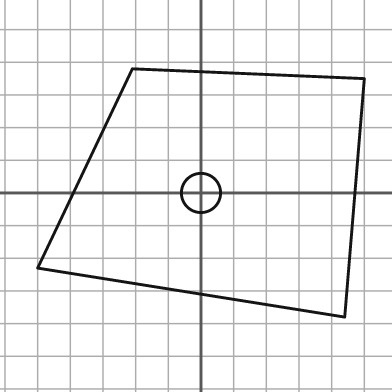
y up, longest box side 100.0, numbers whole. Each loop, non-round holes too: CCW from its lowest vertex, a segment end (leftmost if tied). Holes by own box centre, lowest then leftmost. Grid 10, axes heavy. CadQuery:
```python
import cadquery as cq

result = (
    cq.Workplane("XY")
    .moveTo(44.0, -38.0)
    .lineTo(50.0, 35.0)
    .lineTo(-21.0, 38.0)
    .lineTo(-50.0, -23.0)
    .close()
    .moveTo(0.0, 0.0)
    .circle(6.0)
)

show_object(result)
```